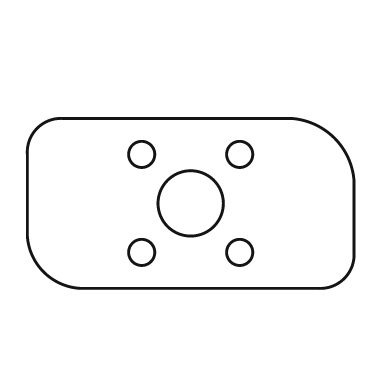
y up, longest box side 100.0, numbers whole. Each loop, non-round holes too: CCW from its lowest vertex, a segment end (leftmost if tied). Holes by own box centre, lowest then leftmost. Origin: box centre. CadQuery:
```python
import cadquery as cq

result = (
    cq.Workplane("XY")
    .moveTo(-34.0, -26.0)
    .lineTo(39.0, -26.0)
    .threePointArc((47.0, -23.0), (50.0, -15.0))
    .lineTo(50.0, 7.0)
    .threePointArc((44.0, 20.0), (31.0, 26.0))
    .lineTo(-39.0, 26.0)
    .threePointArc((-47.0, 23.0), (-50.0, 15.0))
    .lineTo(-50.0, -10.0)
    .threePointArc((-45.0, -21.0), (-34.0, -26.0))
    .close()
    .moveTo(-15.0, -15.0)
    .circle(4.0)
    .moveTo(15.0, -15.0)
    .circle(4.0)
    .moveTo(0.0, 0.0)
    .circle(10.0)
    .moveTo(-15.0, 15.0)
    .circle(4.0)
    .moveTo(15.0, 15.0)
    .circle(4.0)
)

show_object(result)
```